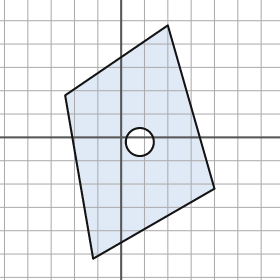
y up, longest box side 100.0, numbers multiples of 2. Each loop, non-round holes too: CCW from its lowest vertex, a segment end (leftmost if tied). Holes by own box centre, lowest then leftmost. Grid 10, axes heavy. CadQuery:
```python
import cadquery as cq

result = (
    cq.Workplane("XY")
    .moveTo(-12.0, -52.0)
    .lineTo(40.0, -22.0)
    .lineTo(20.0, 48.0)
    .lineTo(-24.0, 18.0)
    .close()
    .moveTo(8.0, -2.0)
    .circle(6.0)
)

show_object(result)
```